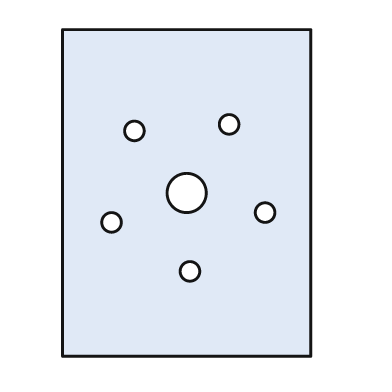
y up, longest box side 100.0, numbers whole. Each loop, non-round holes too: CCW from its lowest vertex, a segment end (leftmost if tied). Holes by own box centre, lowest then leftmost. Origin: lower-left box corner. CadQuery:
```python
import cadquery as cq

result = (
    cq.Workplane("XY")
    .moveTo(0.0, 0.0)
    .lineTo(76.0, 0.0)
    .lineTo(76.0, 100.0)
    .lineTo(0.0, 100.0)
    .close()
    .moveTo(39.0, 26.0)
    .circle(3.0)
    .moveTo(15.0, 41.0)
    .circle(3.0)
    .moveTo(62.0, 44.0)
    .circle(3.0)
    .moveTo(38.0, 50.0)
    .circle(6.0)
    .moveTo(22.0, 69.0)
    .circle(3.0)
    .moveTo(51.0, 71.0)
    .circle(3.0)
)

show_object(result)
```